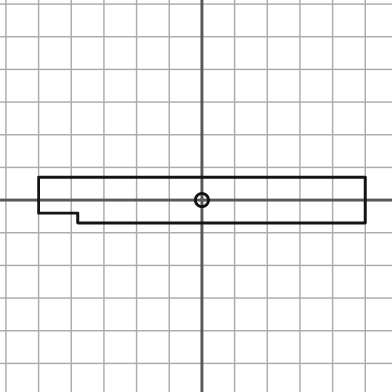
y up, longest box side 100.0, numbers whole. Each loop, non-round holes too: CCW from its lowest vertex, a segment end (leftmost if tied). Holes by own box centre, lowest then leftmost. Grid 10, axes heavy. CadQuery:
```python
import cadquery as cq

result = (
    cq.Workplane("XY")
    .moveTo(-38.0, -7.0)
    .lineTo(50.0, -7.0)
    .lineTo(50.0, 7.0)
    .lineTo(-50.0, 7.0)
    .lineTo(-50.0, -4.0)
    .lineTo(-38.0, -4.0)
    .close()
    .moveTo(0.0, 0.0)
    .circle(2.0)
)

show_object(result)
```